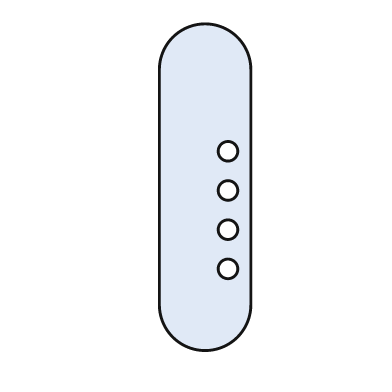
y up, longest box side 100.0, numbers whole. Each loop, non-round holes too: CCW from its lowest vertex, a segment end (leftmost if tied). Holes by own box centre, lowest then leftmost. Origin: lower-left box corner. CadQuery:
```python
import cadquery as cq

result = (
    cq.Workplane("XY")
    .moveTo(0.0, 14.0)
    .threePointArc((14.0, 0.0), (28.0, 14.0))
    .lineTo(28.0, 86.0)
    .threePointArc((14.0, 100.0), (0.0, 86.0))
    .close()
    .moveTo(21.0, 25.0)
    .circle(3.0)
    .moveTo(21.0, 37.0)
    .circle(3.0)
    .moveTo(21.0, 49.0)
    .circle(3.0)
    .moveTo(21.0, 61.0)
    .circle(3.0)
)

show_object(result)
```